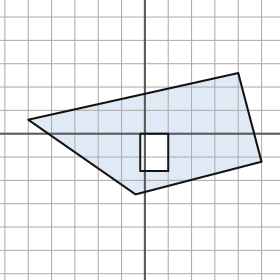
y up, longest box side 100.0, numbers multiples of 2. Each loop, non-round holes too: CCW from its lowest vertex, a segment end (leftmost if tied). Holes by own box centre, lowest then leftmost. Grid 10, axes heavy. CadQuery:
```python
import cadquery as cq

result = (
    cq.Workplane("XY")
    .moveTo(-4.0, -26.0)
    .lineTo(50.0, -12.0)
    .lineTo(40.0, 26.0)
    .lineTo(-50.0, 6.0)
    .close()
    .moveTo(-2.0, -16.0)
    .lineTo(10.0, -16.0)
    .lineTo(10.0, 0.0)
    .lineTo(-2.0, 0.0)
    .close()
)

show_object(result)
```